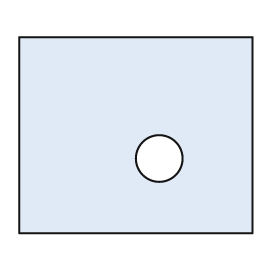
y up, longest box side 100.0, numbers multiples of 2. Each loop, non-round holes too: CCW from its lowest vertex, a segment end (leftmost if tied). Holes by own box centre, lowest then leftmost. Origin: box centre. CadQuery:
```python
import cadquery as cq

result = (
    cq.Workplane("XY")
    .moveTo(-50.0, -42.0)
    .lineTo(50.0, -42.0)
    .lineTo(50.0, 42.0)
    .lineTo(-50.0, 42.0)
    .close()
    .moveTo(10.0, -10.0)
    .circle(10.0)
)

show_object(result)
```